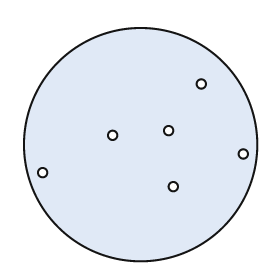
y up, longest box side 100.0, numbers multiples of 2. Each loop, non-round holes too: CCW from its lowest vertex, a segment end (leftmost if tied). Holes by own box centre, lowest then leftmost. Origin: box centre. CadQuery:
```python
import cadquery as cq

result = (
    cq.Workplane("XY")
    .moveTo(0.0, 0.0)
    .circle(50.0)
    .moveTo(14.0, -18.0)
    .circle(2.0)
    .moveTo(-42.0, -12.0)
    .circle(2.0)
    .moveTo(44.0, -4.0)
    .circle(2.0)
    .moveTo(-12.0, 4.0)
    .circle(2.0)
    .moveTo(12.0, 6.0)
    .circle(2.0)
    .moveTo(26.0, 26.0)
    .circle(2.0)
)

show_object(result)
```